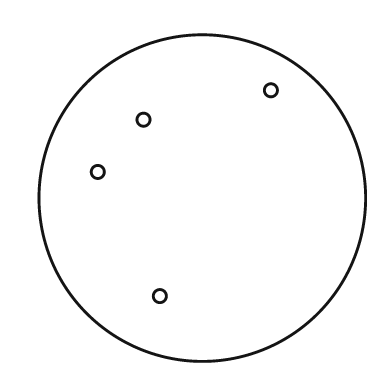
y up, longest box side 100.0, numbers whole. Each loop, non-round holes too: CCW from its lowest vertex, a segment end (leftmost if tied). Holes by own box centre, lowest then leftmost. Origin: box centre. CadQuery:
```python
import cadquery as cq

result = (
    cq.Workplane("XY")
    .moveTo(0.0, 0.0)
    .circle(50.0)
    .moveTo(-13.0, -30.0)
    .circle(2.0)
    .moveTo(-32.0, 8.0)
    .circle(2.0)
    .moveTo(-18.0, 24.0)
    .circle(2.0)
    .moveTo(21.0, 33.0)
    .circle(2.0)
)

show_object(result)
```